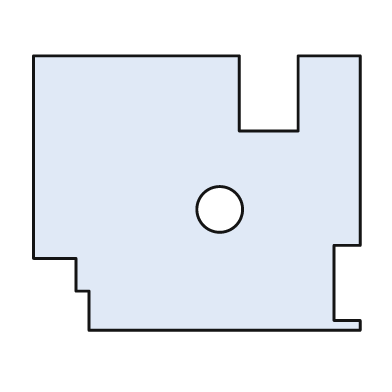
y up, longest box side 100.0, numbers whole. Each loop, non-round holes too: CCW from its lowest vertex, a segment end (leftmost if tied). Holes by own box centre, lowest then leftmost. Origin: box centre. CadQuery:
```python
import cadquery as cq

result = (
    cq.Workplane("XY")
    .moveTo(-33.0, -42.0)
    .lineTo(50.0, -42.0)
    .lineTo(50.0, -39.0)
    .lineTo(42.0, -39.0)
    .lineTo(42.0, -16.0)
    .lineTo(50.0, -16.0)
    .lineTo(50.0, 42.0)
    .lineTo(31.0, 42.0)
    .lineTo(31.0, 19.0)
    .lineTo(13.0, 19.0)
    .lineTo(13.0, 42.0)
    .lineTo(-50.0, 42.0)
    .lineTo(-50.0, -20.0)
    .lineTo(-37.0, -20.0)
    .lineTo(-37.0, -30.0)
    .lineTo(-33.0, -30.0)
    .close()
    .moveTo(7.0, -5.0)
    .circle(7.0)
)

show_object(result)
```